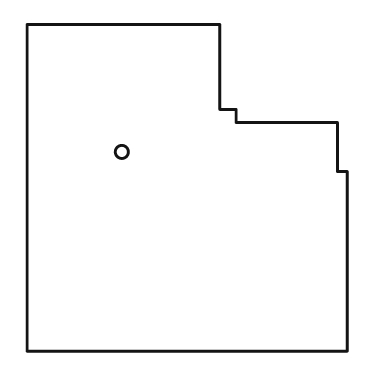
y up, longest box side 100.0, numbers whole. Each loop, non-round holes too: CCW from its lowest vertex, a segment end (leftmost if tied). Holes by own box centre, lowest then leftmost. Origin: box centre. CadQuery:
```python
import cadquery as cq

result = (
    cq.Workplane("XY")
    .moveTo(-49.0, -50.0)
    .lineTo(49.0, -50.0)
    .lineTo(49.0, 5.0)
    .lineTo(46.0, 5.0)
    .lineTo(46.0, 20.0)
    .lineTo(15.0, 20.0)
    .lineTo(15.0, 24.0)
    .lineTo(10.0, 24.0)
    .lineTo(10.0, 50.0)
    .lineTo(-49.0, 50.0)
    .close()
    .moveTo(-20.0, 11.0)
    .circle(2.0)
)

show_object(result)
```